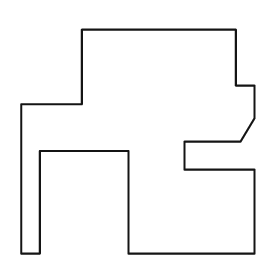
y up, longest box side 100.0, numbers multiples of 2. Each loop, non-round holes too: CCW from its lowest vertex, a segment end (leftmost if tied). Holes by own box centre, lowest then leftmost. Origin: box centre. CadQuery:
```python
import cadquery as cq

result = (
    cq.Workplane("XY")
    .moveTo(-50.0, -48.0)
    .lineTo(-42.0, -48.0)
    .lineTo(-42.0, -4.0)
    .lineTo(-4.0, -4.0)
    .lineTo(-4.0, -48.0)
    .lineTo(50.0, -48.0)
    .lineTo(50.0, -12.0)
    .lineTo(20.0, -12.0)
    .lineTo(20.0, 0.0)
    .lineTo(44.0, 0.0)
    .lineTo(50.0, 10.0)
    .lineTo(50.0, 24.0)
    .lineTo(42.0, 24.0)
    .lineTo(42.0, 48.0)
    .lineTo(-24.0, 48.0)
    .lineTo(-24.0, 16.0)
    .lineTo(-50.0, 16.0)
    .close()
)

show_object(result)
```